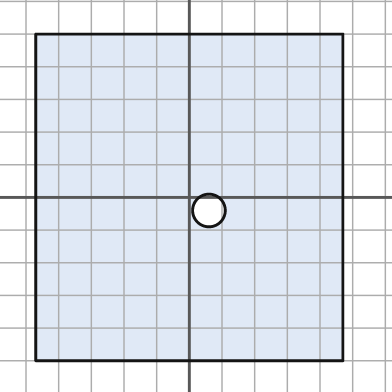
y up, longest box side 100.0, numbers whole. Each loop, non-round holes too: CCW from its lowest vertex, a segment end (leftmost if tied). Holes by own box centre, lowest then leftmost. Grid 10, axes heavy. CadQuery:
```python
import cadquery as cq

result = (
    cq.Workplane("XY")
    .moveTo(-47.0, -50.0)
    .lineTo(47.0, -50.0)
    .lineTo(47.0, 50.0)
    .lineTo(-47.0, 50.0)
    .close()
    .moveTo(6.0, -4.0)
    .circle(5.0)
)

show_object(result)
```